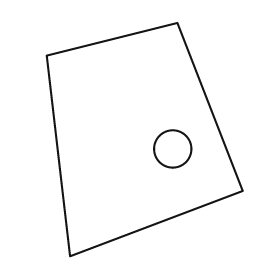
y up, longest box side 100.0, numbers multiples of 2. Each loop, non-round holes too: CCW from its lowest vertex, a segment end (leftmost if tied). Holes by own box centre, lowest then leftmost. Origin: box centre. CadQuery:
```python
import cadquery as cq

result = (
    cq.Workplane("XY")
    .moveTo(-32.0, -50.0)
    .lineTo(42.0, -22.0)
    .lineTo(14.0, 50.0)
    .lineTo(-42.0, 36.0)
    .close()
    .moveTo(12.0, -4.0)
    .circle(8.0)
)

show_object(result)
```